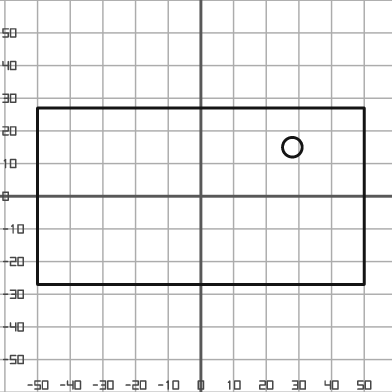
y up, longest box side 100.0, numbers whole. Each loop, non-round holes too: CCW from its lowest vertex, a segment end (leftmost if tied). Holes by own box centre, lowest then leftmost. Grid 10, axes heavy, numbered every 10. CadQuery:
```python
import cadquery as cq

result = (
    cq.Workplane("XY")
    .moveTo(-50.0, -27.0)
    .lineTo(50.0, -27.0)
    .lineTo(50.0, 27.0)
    .lineTo(-50.0, 27.0)
    .close()
    .moveTo(28.0, 15.0)
    .circle(3.0)
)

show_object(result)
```